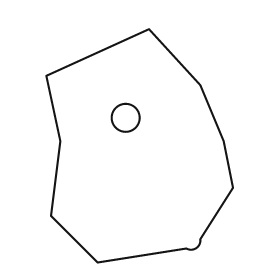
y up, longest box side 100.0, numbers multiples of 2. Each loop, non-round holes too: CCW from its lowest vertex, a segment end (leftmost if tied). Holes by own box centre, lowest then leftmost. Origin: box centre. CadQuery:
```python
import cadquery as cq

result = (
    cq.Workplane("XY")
    .moveTo(-18.0, -50.0)
    .lineTo(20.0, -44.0)
    .threePointArc((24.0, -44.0), (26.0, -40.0))
    .lineTo(40.0, -18.0)
    .lineTo(36.0, 2.0)
    .lineTo(26.0, 26.0)
    .lineTo(4.0, 50.0)
    .lineTo(-40.0, 30.0)
    .lineTo(-34.0, 2.0)
    .lineTo(-38.0, -30.0)
    .close()
    .moveTo(-6.0, 12.0)
    .circle(6.0)
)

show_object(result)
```